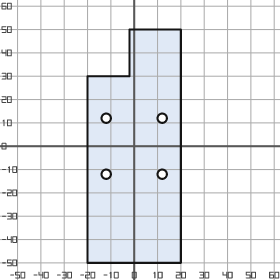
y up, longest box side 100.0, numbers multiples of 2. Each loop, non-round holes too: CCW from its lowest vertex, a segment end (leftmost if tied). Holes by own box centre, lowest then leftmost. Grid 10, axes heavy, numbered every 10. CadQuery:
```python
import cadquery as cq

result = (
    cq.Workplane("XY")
    .moveTo(-20.0, -50.0)
    .lineTo(20.0, -50.0)
    .lineTo(20.0, 50.0)
    .lineTo(-2.0, 50.0)
    .lineTo(-2.0, 30.0)
    .lineTo(-20.0, 30.0)
    .close()
    .moveTo(-12.0, -12.0)
    .circle(2.0)
    .moveTo(12.0, -12.0)
    .circle(2.0)
    .moveTo(-12.0, 12.0)
    .circle(2.0)
    .moveTo(12.0, 12.0)
    .circle(2.0)
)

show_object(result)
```